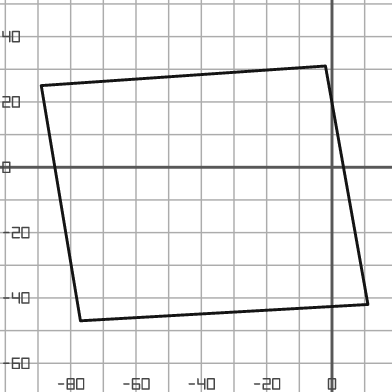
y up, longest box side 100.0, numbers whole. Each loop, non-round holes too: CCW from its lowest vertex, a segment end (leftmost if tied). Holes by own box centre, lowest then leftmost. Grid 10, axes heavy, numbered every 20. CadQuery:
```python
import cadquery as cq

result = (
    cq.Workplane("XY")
    .moveTo(-77.0, -47.0)
    .lineTo(11.0, -42.0)
    .lineTo(-2.0, 31.0)
    .lineTo(-89.0, 25.0)
    .close()
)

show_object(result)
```